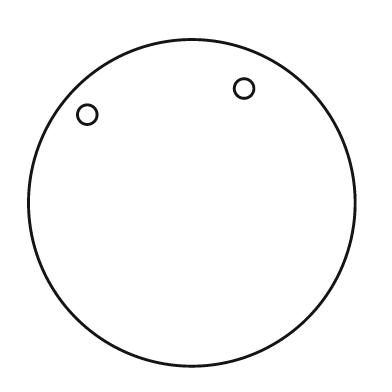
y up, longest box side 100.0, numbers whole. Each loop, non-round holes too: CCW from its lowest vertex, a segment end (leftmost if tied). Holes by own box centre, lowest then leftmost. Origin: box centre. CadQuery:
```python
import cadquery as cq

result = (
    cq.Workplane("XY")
    .moveTo(0.0, 0.0)
    .circle(50.0)
    .moveTo(-32.0, 27.0)
    .circle(3.0)
    .moveTo(16.0, 35.0)
    .circle(3.0)
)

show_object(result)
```